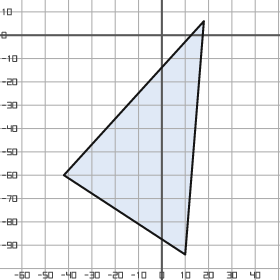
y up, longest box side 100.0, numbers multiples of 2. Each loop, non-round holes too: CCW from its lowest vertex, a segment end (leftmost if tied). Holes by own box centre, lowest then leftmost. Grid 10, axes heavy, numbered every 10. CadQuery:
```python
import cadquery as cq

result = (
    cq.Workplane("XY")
    .moveTo(10.0, -94.0)
    .lineTo(18.0, 6.0)
    .lineTo(-42.0, -60.0)
    .close()
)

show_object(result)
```